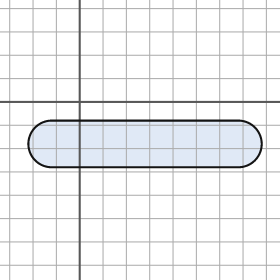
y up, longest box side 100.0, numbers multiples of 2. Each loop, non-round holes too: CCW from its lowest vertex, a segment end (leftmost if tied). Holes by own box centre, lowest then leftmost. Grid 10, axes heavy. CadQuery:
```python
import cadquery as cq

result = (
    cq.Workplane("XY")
    .moveTo(-12.0, -28.0)
    .lineTo(68.0, -28.0)
    .threePointArc((78.0, -18.0), (68.0, -8.0))
    .lineTo(-12.0, -8.0)
    .threePointArc((-22.0, -18.0), (-12.0, -28.0))
    .close()
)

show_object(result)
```